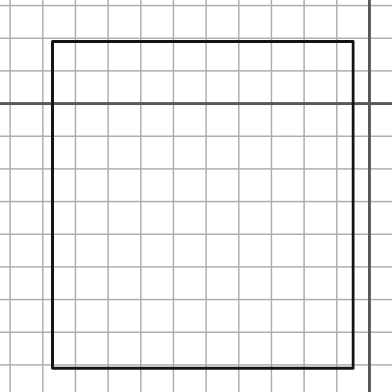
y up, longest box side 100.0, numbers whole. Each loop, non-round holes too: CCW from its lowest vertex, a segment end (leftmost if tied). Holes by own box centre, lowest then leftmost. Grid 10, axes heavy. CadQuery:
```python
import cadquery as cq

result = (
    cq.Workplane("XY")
    .moveTo(-97.0, -81.0)
    .lineTo(-5.0, -81.0)
    .lineTo(-5.0, 19.0)
    .lineTo(-97.0, 19.0)
    .close()
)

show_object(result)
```